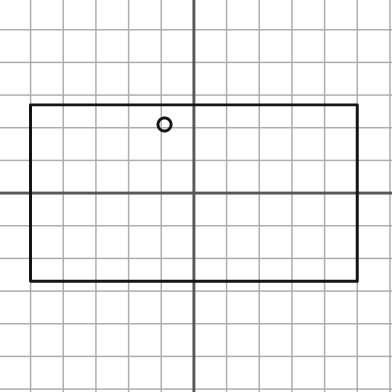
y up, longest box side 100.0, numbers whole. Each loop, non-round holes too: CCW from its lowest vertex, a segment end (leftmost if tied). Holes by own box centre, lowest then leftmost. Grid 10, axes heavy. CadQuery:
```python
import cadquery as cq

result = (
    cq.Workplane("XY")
    .moveTo(-50.0, -27.0)
    .lineTo(50.0, -27.0)
    .lineTo(50.0, 27.0)
    .lineTo(-50.0, 27.0)
    .close()
    .moveTo(-9.0, 21.0)
    .circle(2.0)
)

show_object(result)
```